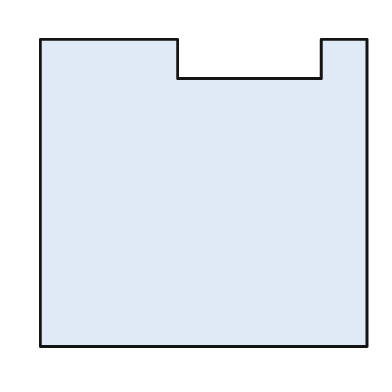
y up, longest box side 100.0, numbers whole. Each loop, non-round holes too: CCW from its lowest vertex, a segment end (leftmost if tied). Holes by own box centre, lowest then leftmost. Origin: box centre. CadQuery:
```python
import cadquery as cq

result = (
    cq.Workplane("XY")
    .moveTo(-50.0, -47.0)
    .lineTo(50.0, -47.0)
    .lineTo(50.0, 47.0)
    .lineTo(36.0, 47.0)
    .lineTo(36.0, 35.0)
    .lineTo(-8.0, 35.0)
    .lineTo(-8.0, 47.0)
    .lineTo(-50.0, 47.0)
    .close()
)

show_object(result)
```